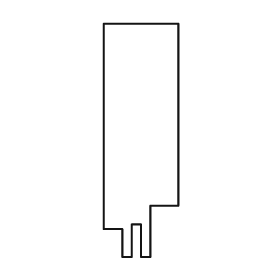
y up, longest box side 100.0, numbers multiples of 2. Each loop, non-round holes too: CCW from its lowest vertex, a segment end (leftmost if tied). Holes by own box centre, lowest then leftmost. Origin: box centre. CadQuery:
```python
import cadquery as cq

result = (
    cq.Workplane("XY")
    .moveTo(-8.0, -50.0)
    .lineTo(-4.0, -50.0)
    .lineTo(-4.0, -36.0)
    .lineTo(0.0, -36.0)
    .lineTo(0.0, -50.0)
    .lineTo(4.0, -50.0)
    .lineTo(4.0, -28.0)
    .lineTo(16.0, -28.0)
    .lineTo(16.0, 50.0)
    .lineTo(-16.0, 50.0)
    .lineTo(-16.0, -38.0)
    .lineTo(-8.0, -38.0)
    .close()
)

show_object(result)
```